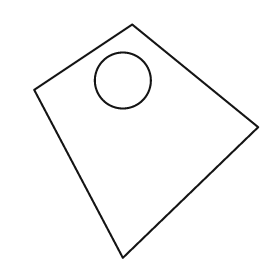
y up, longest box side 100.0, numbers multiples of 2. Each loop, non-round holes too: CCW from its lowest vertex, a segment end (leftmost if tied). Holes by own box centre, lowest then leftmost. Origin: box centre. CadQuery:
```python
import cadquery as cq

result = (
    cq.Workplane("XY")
    .moveTo(-10.0, -50.0)
    .lineTo(48.0, 6.0)
    .lineTo(-6.0, 50.0)
    .lineTo(-48.0, 22.0)
    .close()
    .moveTo(-10.0, 26.0)
    .circle(12.0)
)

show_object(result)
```